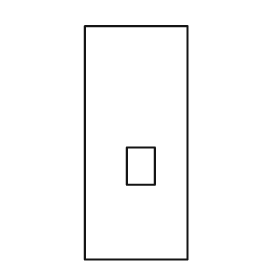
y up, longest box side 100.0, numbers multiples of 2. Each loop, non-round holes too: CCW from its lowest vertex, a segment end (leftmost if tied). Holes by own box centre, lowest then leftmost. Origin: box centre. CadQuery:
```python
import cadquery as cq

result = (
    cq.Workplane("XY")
    .moveTo(-22.0, -50.0)
    .lineTo(22.0, -50.0)
    .lineTo(22.0, 50.0)
    .lineTo(-22.0, 50.0)
    .close()
    .moveTo(-4.0, -18.0)
    .lineTo(8.0, -18.0)
    .lineTo(8.0, -2.0)
    .lineTo(-4.0, -2.0)
    .close()
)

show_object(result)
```